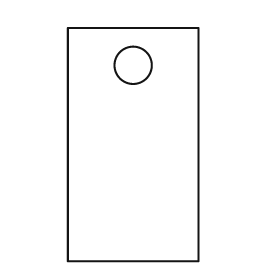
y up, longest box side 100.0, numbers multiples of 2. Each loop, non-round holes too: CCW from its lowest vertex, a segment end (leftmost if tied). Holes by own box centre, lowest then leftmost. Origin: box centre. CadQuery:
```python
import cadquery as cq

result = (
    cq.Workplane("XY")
    .moveTo(-28.0, -50.0)
    .lineTo(28.0, -50.0)
    .lineTo(28.0, 50.0)
    .lineTo(-28.0, 50.0)
    .close()
    .moveTo(0.0, 34.0)
    .circle(8.0)
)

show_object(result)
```